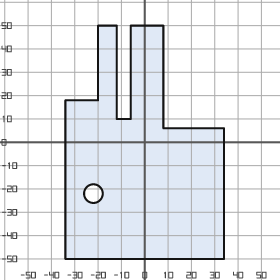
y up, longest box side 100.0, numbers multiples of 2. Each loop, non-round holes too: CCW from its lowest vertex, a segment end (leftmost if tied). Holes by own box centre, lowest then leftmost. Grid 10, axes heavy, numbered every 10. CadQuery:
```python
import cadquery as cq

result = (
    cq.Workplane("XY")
    .moveTo(-34.0, -50.0)
    .lineTo(34.0, -50.0)
    .lineTo(34.0, 6.0)
    .lineTo(8.0, 6.0)
    .lineTo(8.0, 50.0)
    .lineTo(-6.0, 50.0)
    .lineTo(-6.0, 10.0)
    .lineTo(-12.0, 10.0)
    .lineTo(-12.0, 50.0)
    .lineTo(-20.0, 50.0)
    .lineTo(-20.0, 18.0)
    .lineTo(-34.0, 18.0)
    .close()
    .moveTo(-22.0, -22.0)
    .circle(4.0)
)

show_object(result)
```